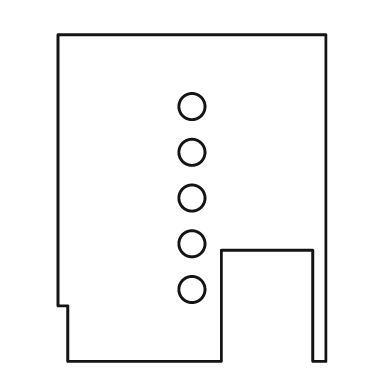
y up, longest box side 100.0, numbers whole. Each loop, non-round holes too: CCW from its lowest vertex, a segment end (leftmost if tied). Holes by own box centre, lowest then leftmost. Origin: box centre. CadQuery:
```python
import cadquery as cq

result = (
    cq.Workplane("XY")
    .moveTo(-38.0, -50.0)
    .lineTo(9.0, -50.0)
    .lineTo(9.0, -16.0)
    .lineTo(37.0, -16.0)
    .lineTo(37.0, -50.0)
    .lineTo(41.0, -50.0)
    .lineTo(41.0, 50.0)
    .lineTo(-41.0, 50.0)
    .lineTo(-41.0, -33.0)
    .lineTo(-38.0, -33.0)
    .close()
    .moveTo(0.0, -28.0)
    .circle(4.0)
    .moveTo(0.0, -14.0)
    .circle(4.0)
    .moveTo(0.0, 0.0)
    .circle(4.0)
    .moveTo(0.0, 14.0)
    .circle(4.0)
    .moveTo(0.0, 28.0)
    .circle(4.0)
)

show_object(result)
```